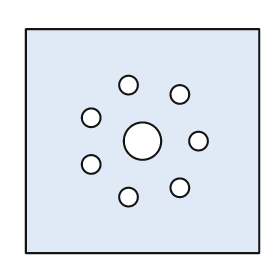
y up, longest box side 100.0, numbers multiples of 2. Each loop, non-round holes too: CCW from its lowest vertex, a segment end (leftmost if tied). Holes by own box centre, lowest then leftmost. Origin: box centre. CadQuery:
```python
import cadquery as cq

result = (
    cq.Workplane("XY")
    .moveTo(-50.0, -48.0)
    .lineTo(50.0, -48.0)
    .lineTo(50.0, 48.0)
    .lineTo(-50.0, 48.0)
    .close()
    .moveTo(-6.0, -24.0)
    .circle(4.0)
    .moveTo(16.0, -20.0)
    .circle(4.0)
    .moveTo(-22.0, -10.0)
    .circle(4.0)
    .moveTo(0.0, 0.0)
    .circle(8.0)
    .moveTo(24.0, 0.0)
    .circle(4.0)
    .moveTo(-22.0, 10.0)
    .circle(4.0)
    .moveTo(16.0, 20.0)
    .circle(4.0)
    .moveTo(-6.0, 24.0)
    .circle(4.0)
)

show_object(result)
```